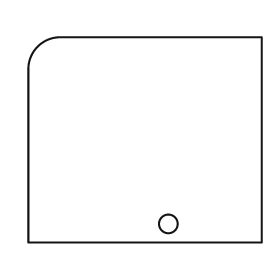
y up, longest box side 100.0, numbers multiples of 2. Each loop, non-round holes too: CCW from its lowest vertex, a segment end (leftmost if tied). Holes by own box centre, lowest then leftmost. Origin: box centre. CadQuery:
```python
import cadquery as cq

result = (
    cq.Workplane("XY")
    .moveTo(-50.0, -44.0)
    .lineTo(50.0, -44.0)
    .lineTo(50.0, 44.0)
    .lineTo(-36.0, 44.0)
    .threePointArc((-46.0, 40.0), (-50.0, 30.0))
    .close()
    .moveTo(10.0, -36.0)
    .circle(4.0)
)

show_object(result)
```